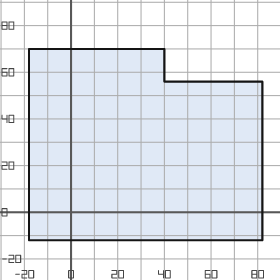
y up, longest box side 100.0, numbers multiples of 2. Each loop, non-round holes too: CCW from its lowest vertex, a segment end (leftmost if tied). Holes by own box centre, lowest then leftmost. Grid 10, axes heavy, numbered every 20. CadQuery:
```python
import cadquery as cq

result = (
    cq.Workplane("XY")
    .moveTo(-18.0, -12.0)
    .lineTo(82.0, -12.0)
    .lineTo(82.0, 56.0)
    .lineTo(40.0, 56.0)
    .lineTo(40.0, 70.0)
    .lineTo(-18.0, 70.0)
    .close()
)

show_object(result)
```